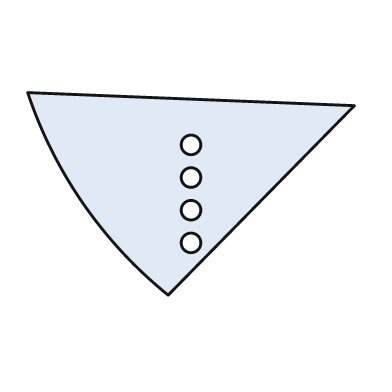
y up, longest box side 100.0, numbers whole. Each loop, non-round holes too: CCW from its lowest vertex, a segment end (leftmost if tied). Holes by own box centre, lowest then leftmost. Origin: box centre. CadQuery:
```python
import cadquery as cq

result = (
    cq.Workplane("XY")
    .moveTo(-7.0, -31.0)
    .lineTo(50.0, 27.0)
    .lineTo(-50.0, 31.0)
    .threePointArc((-33.0, -3.0), (-7.0, -31.0))
    .close()
    .moveTo(0.0, -15.0)
    .circle(3.0)
    .moveTo(0.0, -5.0)
    .circle(3.0)
    .moveTo(0.0, 5.0)
    .circle(3.0)
    .moveTo(0.0, 15.0)
    .circle(3.0)
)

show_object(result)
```